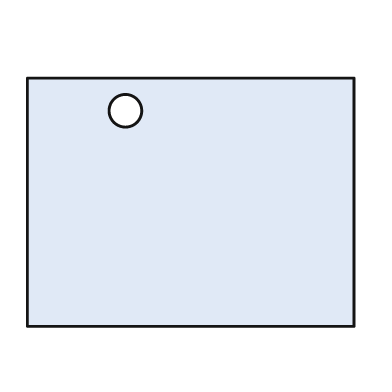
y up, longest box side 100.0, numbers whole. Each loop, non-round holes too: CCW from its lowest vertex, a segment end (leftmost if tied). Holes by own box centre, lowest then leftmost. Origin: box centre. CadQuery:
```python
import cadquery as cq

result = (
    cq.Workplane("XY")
    .moveTo(-50.0, -38.0)
    .lineTo(50.0, -38.0)
    .lineTo(50.0, 38.0)
    .lineTo(-50.0, 38.0)
    .close()
    .moveTo(-20.0, 28.0)
    .circle(5.0)
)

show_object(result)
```